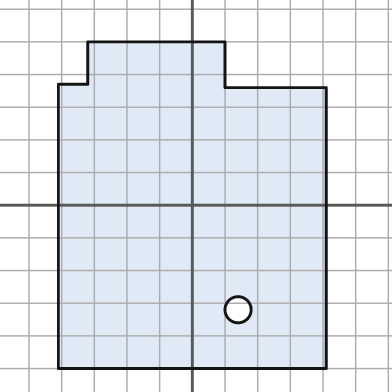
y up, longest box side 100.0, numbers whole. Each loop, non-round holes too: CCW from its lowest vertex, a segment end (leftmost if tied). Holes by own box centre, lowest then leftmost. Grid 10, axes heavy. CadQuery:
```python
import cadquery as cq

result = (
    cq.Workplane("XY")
    .moveTo(-41.0, -50.0)
    .lineTo(41.0, -50.0)
    .lineTo(41.0, 36.0)
    .lineTo(10.0, 36.0)
    .lineTo(10.0, 50.0)
    .lineTo(-32.0, 50.0)
    .lineTo(-32.0, 37.0)
    .lineTo(-41.0, 37.0)
    .close()
    .moveTo(14.0, -32.0)
    .circle(4.0)
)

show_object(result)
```